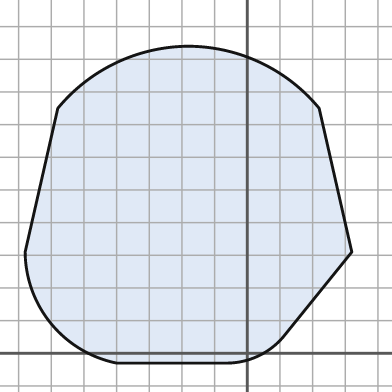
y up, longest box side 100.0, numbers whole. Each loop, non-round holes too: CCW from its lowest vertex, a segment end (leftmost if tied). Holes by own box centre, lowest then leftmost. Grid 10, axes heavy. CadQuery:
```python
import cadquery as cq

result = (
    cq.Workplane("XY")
    .moveTo(-40.0, -3.0)
    .lineTo(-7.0, -3.0)
    .threePointArc((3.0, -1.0), (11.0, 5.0))
    .lineTo(32.0, 31.0)
    .lineTo(22.0, 75.0)
    .threePointArc((4.0, 89.0), (-18.0, 94.0))
    .threePointArc((-40.0, 89.0), (-58.0, 75.0))
    .lineTo(-68.0, 31.0)
    .threePointArc((-60.0, 9.0), (-40.0, -3.0))
    .close()
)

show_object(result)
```